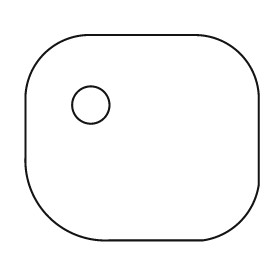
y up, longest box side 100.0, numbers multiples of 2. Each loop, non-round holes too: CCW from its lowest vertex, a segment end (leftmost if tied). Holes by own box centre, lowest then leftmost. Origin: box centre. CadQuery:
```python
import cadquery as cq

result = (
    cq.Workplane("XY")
    .moveTo(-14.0, -44.0)
    .lineTo(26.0, -44.0)
    .threePointArc((42.0, -36.0), (50.0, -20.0))
    .lineTo(50.0, 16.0)
    .threePointArc((42.0, 36.0), (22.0, 44.0))
    .lineTo(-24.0, 44.0)
    .threePointArc((-42.0, 36.0), (-50.0, 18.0))
    .lineTo(-50.0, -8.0)
    .threePointArc((-40.0, -34.0), (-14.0, -44.0))
    .close()
    .moveTo(-22.0, 14.0)
    .circle(8.0)
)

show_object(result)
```